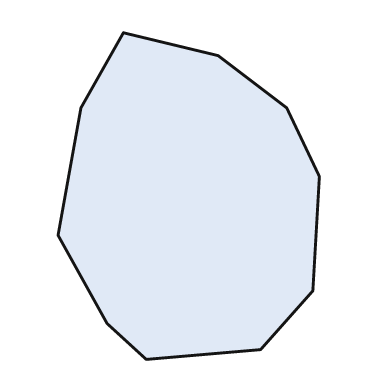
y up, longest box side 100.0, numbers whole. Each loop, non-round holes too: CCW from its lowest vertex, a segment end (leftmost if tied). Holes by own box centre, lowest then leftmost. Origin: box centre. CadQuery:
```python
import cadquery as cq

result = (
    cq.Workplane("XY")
    .moveTo(-13.0, -50.0)
    .lineTo(22.0, -47.0)
    .lineTo(38.0, -29.0)
    .lineTo(40.0, 6.0)
    .lineTo(30.0, 27.0)
    .lineTo(9.0, 43.0)
    .lineTo(-20.0, 50.0)
    .lineTo(-33.0, 27.0)
    .lineTo(-40.0, -12.0)
    .lineTo(-25.0, -39.0)
    .close()
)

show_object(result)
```